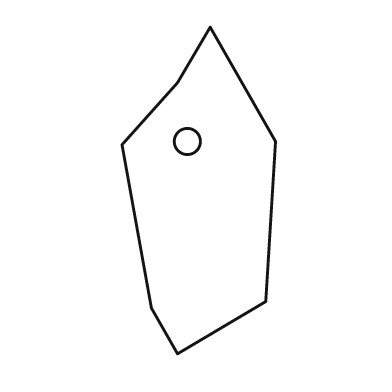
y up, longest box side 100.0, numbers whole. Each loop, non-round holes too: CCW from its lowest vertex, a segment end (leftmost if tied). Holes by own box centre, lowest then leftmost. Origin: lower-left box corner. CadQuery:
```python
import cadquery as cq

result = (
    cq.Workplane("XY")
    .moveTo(17.0, 0.0)
    .lineTo(44.0, 16.0)
    .lineTo(47.0, 65.0)
    .lineTo(27.0, 100.0)
    .lineTo(17.0, 83.0)
    .lineTo(0.0, 64.0)
    .lineTo(9.0, 14.0)
    .close()
    .moveTo(20.0, 65.0)
    .circle(4.0)
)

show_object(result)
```